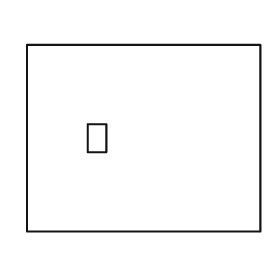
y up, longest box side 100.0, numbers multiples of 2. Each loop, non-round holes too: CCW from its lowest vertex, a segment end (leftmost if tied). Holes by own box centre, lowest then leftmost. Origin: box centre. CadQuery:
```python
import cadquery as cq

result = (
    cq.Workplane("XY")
    .moveTo(-50.0, -40.0)
    .lineTo(50.0, -40.0)
    .lineTo(50.0, 40.0)
    .lineTo(-50.0, 40.0)
    .close()
    .moveTo(-24.0, -6.0)
    .lineTo(-16.0, -6.0)
    .lineTo(-16.0, 6.0)
    .lineTo(-24.0, 6.0)
    .close()
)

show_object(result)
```